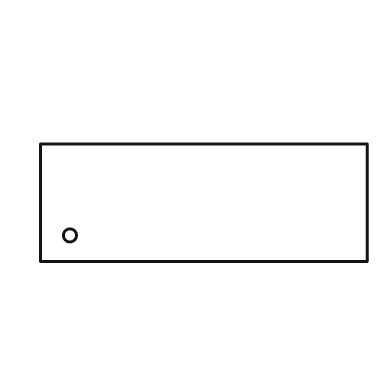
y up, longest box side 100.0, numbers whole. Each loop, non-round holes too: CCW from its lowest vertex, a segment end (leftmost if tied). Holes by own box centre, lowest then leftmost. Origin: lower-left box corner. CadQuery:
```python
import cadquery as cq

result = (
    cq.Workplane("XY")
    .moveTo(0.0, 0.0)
    .lineTo(100.0, 0.0)
    .lineTo(100.0, 36.0)
    .lineTo(0.0, 36.0)
    .close()
    .moveTo(9.0, 8.0)
    .circle(2.0)
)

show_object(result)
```